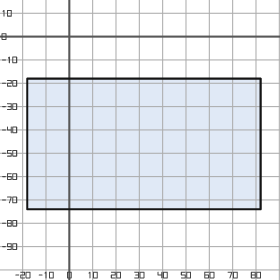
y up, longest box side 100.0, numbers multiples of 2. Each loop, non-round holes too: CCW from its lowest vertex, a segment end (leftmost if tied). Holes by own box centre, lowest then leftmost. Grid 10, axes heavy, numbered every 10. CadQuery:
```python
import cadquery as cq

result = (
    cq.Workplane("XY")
    .moveTo(-18.0, -74.0)
    .lineTo(82.0, -74.0)
    .lineTo(82.0, -18.0)
    .lineTo(-18.0, -18.0)
    .close()
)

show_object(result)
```